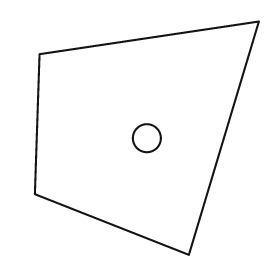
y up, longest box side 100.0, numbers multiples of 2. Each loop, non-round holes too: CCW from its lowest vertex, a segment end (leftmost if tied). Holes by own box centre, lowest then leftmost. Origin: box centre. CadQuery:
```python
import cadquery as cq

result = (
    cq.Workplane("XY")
    .moveTo(18.0, -50.0)
    .lineTo(48.0, 50.0)
    .lineTo(-46.0, 36.0)
    .lineTo(-48.0, -24.0)
    .close()
    .moveTo(0.0, 0.0)
    .circle(6.0)
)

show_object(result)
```